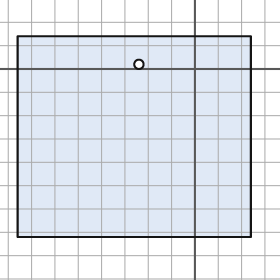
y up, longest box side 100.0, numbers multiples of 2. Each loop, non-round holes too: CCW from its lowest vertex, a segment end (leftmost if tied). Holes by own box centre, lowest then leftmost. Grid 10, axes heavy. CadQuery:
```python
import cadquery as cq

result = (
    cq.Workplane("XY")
    .moveTo(-76.0, -72.0)
    .lineTo(24.0, -72.0)
    .lineTo(24.0, 14.0)
    .lineTo(-76.0, 14.0)
    .close()
    .moveTo(-24.0, 2.0)
    .circle(2.0)
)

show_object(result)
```